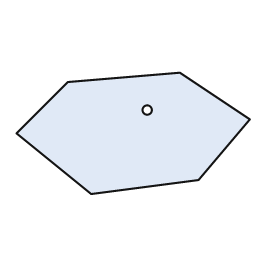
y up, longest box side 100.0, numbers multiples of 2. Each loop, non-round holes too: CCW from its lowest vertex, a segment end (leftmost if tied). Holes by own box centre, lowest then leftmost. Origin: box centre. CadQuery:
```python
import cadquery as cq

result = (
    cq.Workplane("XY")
    .moveTo(-18.0, -26.0)
    .lineTo(28.0, -20.0)
    .lineTo(50.0, 6.0)
    .lineTo(20.0, 26.0)
    .lineTo(-28.0, 22.0)
    .lineTo(-50.0, 0.0)
    .close()
    .moveTo(6.0, 10.0)
    .circle(2.0)
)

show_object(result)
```